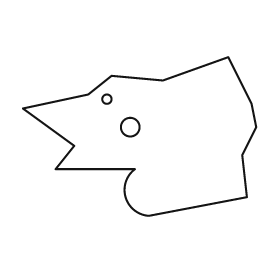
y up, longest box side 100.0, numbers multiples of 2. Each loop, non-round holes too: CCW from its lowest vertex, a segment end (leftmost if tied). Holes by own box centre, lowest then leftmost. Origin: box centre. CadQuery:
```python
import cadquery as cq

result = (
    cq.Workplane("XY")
    .moveTo(4.0, -34.0)
    .lineTo(46.0, -26.0)
    .lineTo(44.0, -8.0)
    .lineTo(50.0, 4.0)
    .lineTo(48.0, 14.0)
    .lineTo(38.0, 34.0)
    .lineTo(10.0, 24.0)
    .lineTo(-12.0, 26.0)
    .lineTo(-22.0, 18.0)
    .lineTo(-50.0, 12.0)
    .lineTo(-28.0, -4.0)
    .lineTo(-36.0, -14.0)
    .lineTo(-2.0, -14.0)
    .threePointArc((-6.0, -26.0), (4.0, -34.0))
    .close()
    .moveTo(-4.0, 4.0)
    .circle(4.0)
    .moveTo(-14.0, 16.0)
    .circle(2.0)
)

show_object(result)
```